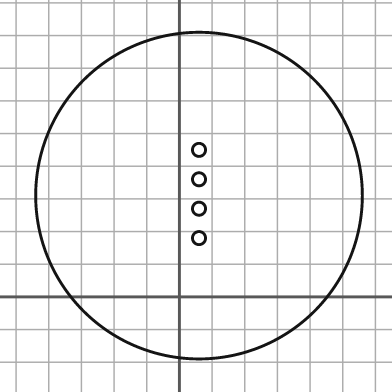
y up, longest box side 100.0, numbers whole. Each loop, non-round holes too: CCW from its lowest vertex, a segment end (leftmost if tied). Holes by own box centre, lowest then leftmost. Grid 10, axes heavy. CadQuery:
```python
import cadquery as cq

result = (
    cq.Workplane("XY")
    .moveTo(6.0, 31.0)
    .circle(50.0)
    .moveTo(6.0, 18.0)
    .circle(2.0)
    .moveTo(6.0, 27.0)
    .circle(2.0)
    .moveTo(6.0, 36.0)
    .circle(2.0)
    .moveTo(6.0, 45.0)
    .circle(2.0)
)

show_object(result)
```